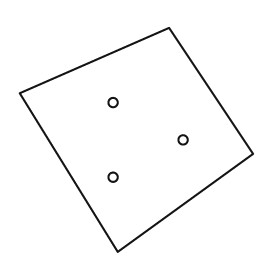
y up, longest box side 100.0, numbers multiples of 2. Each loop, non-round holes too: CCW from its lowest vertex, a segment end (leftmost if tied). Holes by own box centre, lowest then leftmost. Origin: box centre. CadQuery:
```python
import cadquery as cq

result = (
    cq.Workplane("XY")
    .moveTo(-8.0, -48.0)
    .lineTo(50.0, -6.0)
    .lineTo(14.0, 48.0)
    .lineTo(-50.0, 20.0)
    .close()
    .moveTo(-10.0, -16.0)
    .circle(2.0)
    .moveTo(20.0, 0.0)
    .circle(2.0)
    .moveTo(-10.0, 16.0)
    .circle(2.0)
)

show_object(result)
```